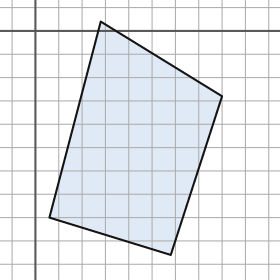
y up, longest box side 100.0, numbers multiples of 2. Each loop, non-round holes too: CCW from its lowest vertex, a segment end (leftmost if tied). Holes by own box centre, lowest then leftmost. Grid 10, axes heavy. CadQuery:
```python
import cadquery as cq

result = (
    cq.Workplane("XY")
    .moveTo(58.0, -96.0)
    .lineTo(80.0, -28.0)
    .lineTo(28.0, 4.0)
    .lineTo(6.0, -80.0)
    .close()
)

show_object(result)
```